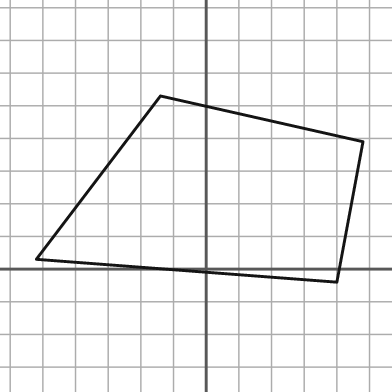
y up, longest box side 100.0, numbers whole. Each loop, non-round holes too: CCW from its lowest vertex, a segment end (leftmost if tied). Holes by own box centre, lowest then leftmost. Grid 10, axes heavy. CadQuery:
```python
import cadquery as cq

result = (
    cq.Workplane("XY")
    .moveTo(40.0, -4.0)
    .lineTo(48.0, 39.0)
    .lineTo(-14.0, 53.0)
    .lineTo(-52.0, 3.0)
    .close()
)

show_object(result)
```